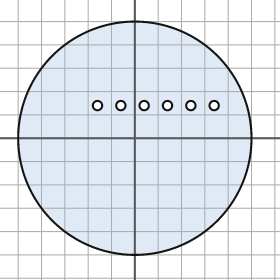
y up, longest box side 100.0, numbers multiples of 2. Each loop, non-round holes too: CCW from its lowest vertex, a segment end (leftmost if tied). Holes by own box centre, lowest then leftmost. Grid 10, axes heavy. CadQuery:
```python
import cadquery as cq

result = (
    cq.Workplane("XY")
    .moveTo(0.0, 0.0)
    .circle(50.0)
    .moveTo(-16.0, 14.0)
    .circle(2.0)
    .moveTo(-6.0, 14.0)
    .circle(2.0)
    .moveTo(4.0, 14.0)
    .circle(2.0)
    .moveTo(14.0, 14.0)
    .circle(2.0)
    .moveTo(24.0, 14.0)
    .circle(2.0)
    .moveTo(34.0, 14.0)
    .circle(2.0)
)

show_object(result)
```